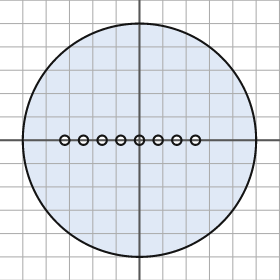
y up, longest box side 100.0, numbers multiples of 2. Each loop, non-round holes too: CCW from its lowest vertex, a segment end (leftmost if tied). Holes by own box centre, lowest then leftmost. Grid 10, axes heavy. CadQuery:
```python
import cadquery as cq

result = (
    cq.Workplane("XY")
    .moveTo(0.0, 0.0)
    .circle(50.0)
    .moveTo(-32.0, 0.0)
    .circle(2.0)
    .moveTo(-24.0, 0.0)
    .circle(2.0)
    .moveTo(-16.0, 0.0)
    .circle(2.0)
    .moveTo(-8.0, 0.0)
    .circle(2.0)
    .moveTo(0.0, 0.0)
    .circle(2.0)
    .moveTo(8.0, 0.0)
    .circle(2.0)
    .moveTo(16.0, 0.0)
    .circle(2.0)
    .moveTo(24.0, 0.0)
    .circle(2.0)
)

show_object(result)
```